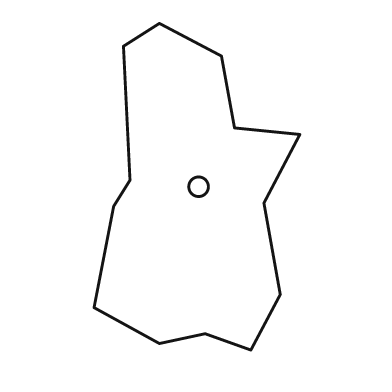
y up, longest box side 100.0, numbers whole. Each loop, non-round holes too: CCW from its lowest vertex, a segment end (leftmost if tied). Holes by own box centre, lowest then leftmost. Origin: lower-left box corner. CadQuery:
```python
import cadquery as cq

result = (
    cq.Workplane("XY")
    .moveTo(48.0, 0.0)
    .lineTo(57.0, 17.0)
    .lineTo(52.0, 45.0)
    .lineTo(63.0, 66.0)
    .lineTo(43.0, 68.0)
    .lineTo(39.0, 90.0)
    .lineTo(20.0, 100.0)
    .lineTo(9.0, 93.0)
    .lineTo(11.0, 52.0)
    .lineTo(6.0, 44.0)
    .lineTo(0.0, 13.0)
    .lineTo(20.0, 2.0)
    .lineTo(34.0, 5.0)
    .close()
    .moveTo(32.0, 50.0)
    .circle(3.0)
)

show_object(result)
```